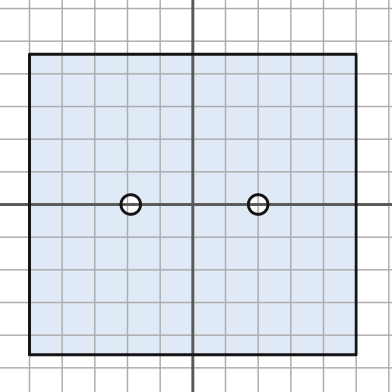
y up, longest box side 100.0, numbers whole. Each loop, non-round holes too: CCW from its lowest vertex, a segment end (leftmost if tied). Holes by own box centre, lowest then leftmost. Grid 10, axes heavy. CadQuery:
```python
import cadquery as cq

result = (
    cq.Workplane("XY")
    .moveTo(-50.0, -46.0)
    .lineTo(50.0, -46.0)
    .lineTo(50.0, 46.0)
    .lineTo(-50.0, 46.0)
    .close()
    .moveTo(-19.0, 0.0)
    .circle(3.0)
    .moveTo(20.0, 0.0)
    .circle(3.0)
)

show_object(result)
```